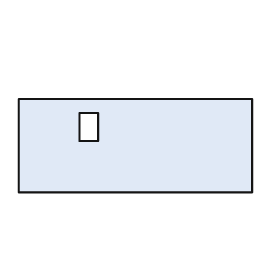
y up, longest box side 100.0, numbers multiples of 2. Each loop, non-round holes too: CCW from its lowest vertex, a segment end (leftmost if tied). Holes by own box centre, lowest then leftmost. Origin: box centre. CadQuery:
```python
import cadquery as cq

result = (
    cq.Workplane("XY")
    .moveTo(-50.0, -20.0)
    .lineTo(50.0, -20.0)
    .lineTo(50.0, 20.0)
    .lineTo(-50.0, 20.0)
    .close()
    .moveTo(-24.0, 2.0)
    .lineTo(-16.0, 2.0)
    .lineTo(-16.0, 14.0)
    .lineTo(-24.0, 14.0)
    .close()
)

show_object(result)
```